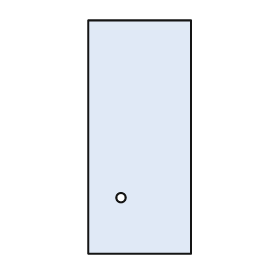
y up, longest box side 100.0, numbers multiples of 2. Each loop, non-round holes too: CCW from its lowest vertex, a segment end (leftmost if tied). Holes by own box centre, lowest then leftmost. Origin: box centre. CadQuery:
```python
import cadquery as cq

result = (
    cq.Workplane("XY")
    .moveTo(-22.0, -50.0)
    .lineTo(22.0, -50.0)
    .lineTo(22.0, 50.0)
    .lineTo(-22.0, 50.0)
    .close()
    .moveTo(-8.0, -26.0)
    .circle(2.0)
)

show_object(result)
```